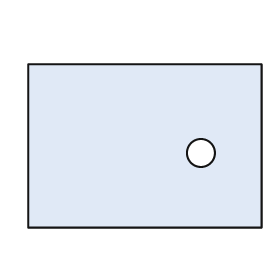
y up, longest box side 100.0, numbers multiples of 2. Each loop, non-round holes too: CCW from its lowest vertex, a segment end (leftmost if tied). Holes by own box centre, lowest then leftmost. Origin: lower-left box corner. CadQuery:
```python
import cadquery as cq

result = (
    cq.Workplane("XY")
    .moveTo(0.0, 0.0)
    .lineTo(100.0, 0.0)
    .lineTo(100.0, 70.0)
    .lineTo(0.0, 70.0)
    .close()
    .moveTo(74.0, 32.0)
    .circle(6.0)
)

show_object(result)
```